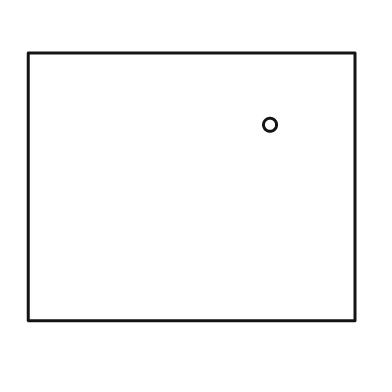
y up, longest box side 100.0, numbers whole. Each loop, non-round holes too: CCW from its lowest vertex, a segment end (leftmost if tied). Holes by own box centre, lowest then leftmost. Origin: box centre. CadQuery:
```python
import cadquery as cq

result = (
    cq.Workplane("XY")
    .moveTo(-50.0, -41.0)
    .lineTo(50.0, -41.0)
    .lineTo(50.0, 41.0)
    .lineTo(-50.0, 41.0)
    .close()
    .moveTo(24.0, 19.0)
    .circle(2.0)
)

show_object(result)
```